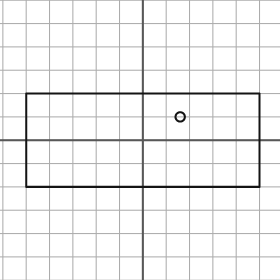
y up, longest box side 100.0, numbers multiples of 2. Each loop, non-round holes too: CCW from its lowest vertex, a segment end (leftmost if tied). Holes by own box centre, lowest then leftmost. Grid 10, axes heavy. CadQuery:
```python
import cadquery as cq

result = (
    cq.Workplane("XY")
    .moveTo(-50.0, -20.0)
    .lineTo(50.0, -20.0)
    .lineTo(50.0, 20.0)
    .lineTo(-50.0, 20.0)
    .close()
    .moveTo(16.0, 10.0)
    .circle(2.0)
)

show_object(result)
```